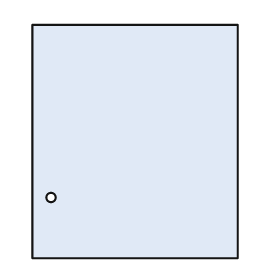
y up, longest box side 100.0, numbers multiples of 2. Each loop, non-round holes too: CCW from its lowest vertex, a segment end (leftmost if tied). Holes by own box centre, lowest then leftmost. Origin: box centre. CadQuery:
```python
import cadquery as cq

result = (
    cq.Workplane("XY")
    .moveTo(-44.0, -50.0)
    .lineTo(44.0, -50.0)
    .lineTo(44.0, 50.0)
    .lineTo(-44.0, 50.0)
    .close()
    .moveTo(-36.0, -24.0)
    .circle(2.0)
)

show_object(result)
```